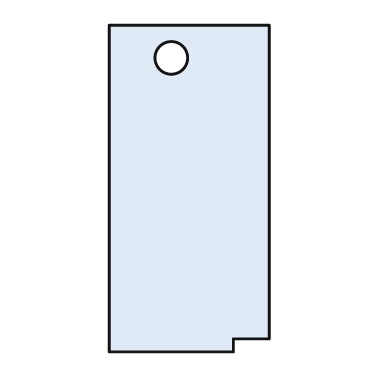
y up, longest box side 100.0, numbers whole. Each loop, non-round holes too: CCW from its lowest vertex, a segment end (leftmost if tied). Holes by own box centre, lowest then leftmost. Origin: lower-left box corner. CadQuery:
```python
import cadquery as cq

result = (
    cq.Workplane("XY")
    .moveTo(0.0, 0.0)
    .lineTo(38.0, 0.0)
    .lineTo(38.0, 4.0)
    .lineTo(49.0, 4.0)
    .lineTo(49.0, 100.0)
    .lineTo(0.0, 100.0)
    .close()
    .moveTo(19.0, 90.0)
    .circle(5.0)
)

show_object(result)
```